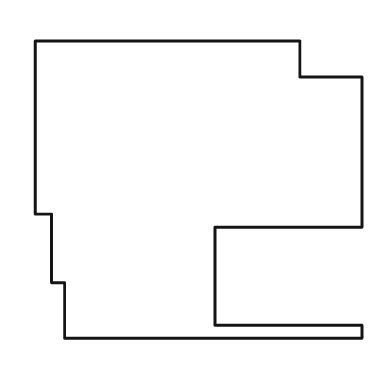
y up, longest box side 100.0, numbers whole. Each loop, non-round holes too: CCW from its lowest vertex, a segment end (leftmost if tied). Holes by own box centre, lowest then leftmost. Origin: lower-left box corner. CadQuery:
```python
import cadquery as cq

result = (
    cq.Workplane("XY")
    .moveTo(9.0, 0.0)
    .lineTo(100.0, 0.0)
    .lineTo(100.0, 4.0)
    .lineTo(55.0, 4.0)
    .lineTo(55.0, 34.0)
    .lineTo(100.0, 34.0)
    .lineTo(100.0, 80.0)
    .lineTo(81.0, 80.0)
    .lineTo(81.0, 91.0)
    .lineTo(0.0, 91.0)
    .lineTo(0.0, 38.0)
    .lineTo(5.0, 38.0)
    .lineTo(5.0, 17.0)
    .lineTo(9.0, 17.0)
    .close()
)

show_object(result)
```